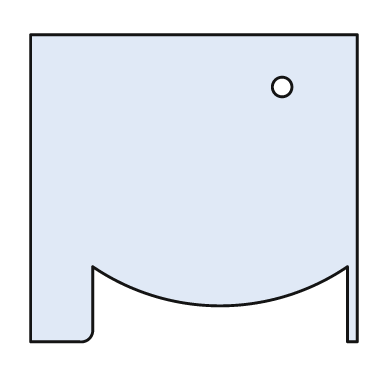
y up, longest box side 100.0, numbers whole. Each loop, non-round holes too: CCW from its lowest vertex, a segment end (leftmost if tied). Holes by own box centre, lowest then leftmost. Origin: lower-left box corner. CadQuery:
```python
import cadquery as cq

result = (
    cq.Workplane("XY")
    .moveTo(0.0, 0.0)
    .lineTo(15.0, 0.0)
    .threePointArc((18.0, 1.0), (19.0, 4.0))
    .lineTo(19.0, 23.0)
    .threePointArc((58.0, 11.0), (97.0, 23.0))
    .lineTo(97.0, 0.0)
    .lineTo(100.0, 0.0)
    .lineTo(100.0, 94.0)
    .lineTo(0.0, 94.0)
    .close()
    .moveTo(77.0, 78.0)
    .circle(3.0)
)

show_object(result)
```